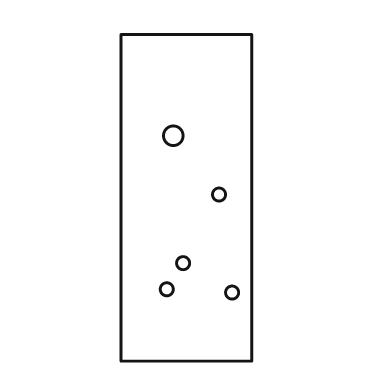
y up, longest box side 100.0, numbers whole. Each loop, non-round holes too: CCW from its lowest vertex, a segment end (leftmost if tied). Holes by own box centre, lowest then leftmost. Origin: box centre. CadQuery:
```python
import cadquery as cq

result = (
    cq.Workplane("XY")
    .moveTo(-20.0, -50.0)
    .lineTo(20.0, -50.0)
    .lineTo(20.0, 50.0)
    .lineTo(-20.0, 50.0)
    .close()
    .moveTo(14.0, -29.0)
    .circle(2.0)
    .moveTo(-6.0, -28.0)
    .circle(2.0)
    .moveTo(-1.0, -20.0)
    .circle(2.0)
    .moveTo(10.0, 1.0)
    .circle(2.0)
    .moveTo(-4.0, 19.0)
    .circle(3.0)
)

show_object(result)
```